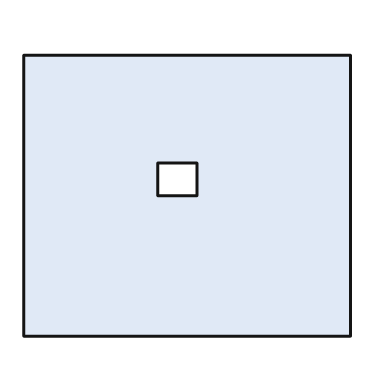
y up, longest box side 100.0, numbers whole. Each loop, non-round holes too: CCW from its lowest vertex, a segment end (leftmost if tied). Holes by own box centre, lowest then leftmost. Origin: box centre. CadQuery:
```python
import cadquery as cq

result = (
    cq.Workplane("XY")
    .moveTo(-50.0, -43.0)
    .lineTo(50.0, -43.0)
    .lineTo(50.0, 43.0)
    .lineTo(-50.0, 43.0)
    .close()
    .moveTo(-9.0, 0.0)
    .lineTo(3.0, 0.0)
    .lineTo(3.0, 10.0)
    .lineTo(-9.0, 10.0)
    .close()
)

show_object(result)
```